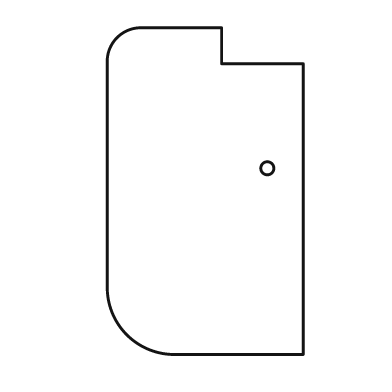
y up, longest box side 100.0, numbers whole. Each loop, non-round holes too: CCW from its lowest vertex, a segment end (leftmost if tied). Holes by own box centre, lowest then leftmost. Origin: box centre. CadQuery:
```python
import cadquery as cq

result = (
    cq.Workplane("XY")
    .moveTo(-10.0, -50.0)
    .lineTo(30.0, -50.0)
    .lineTo(30.0, 39.0)
    .lineTo(5.0, 39.0)
    .lineTo(5.0, 50.0)
    .lineTo(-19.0, 50.0)
    .threePointArc((-27.0, 47.0), (-30.0, 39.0))
    .lineTo(-30.0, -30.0)
    .threePointArc((-24.0, -44.0), (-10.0, -50.0))
    .close()
    .moveTo(19.0, 7.0)
    .circle(2.0)
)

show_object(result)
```